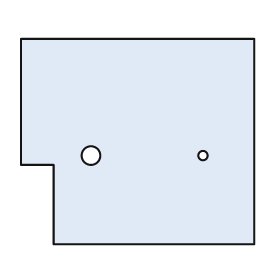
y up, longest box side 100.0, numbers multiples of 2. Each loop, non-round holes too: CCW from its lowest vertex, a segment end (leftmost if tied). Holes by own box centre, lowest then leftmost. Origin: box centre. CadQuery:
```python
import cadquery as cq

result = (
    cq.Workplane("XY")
    .moveTo(-36.0, -44.0)
    .lineTo(50.0, -44.0)
    .lineTo(50.0, 44.0)
    .lineTo(-50.0, 44.0)
    .lineTo(-50.0, -10.0)
    .lineTo(-36.0, -10.0)
    .close()
    .moveTo(-20.0, -6.0)
    .circle(4.0)
    .moveTo(28.0, -6.0)
    .circle(2.0)
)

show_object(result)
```